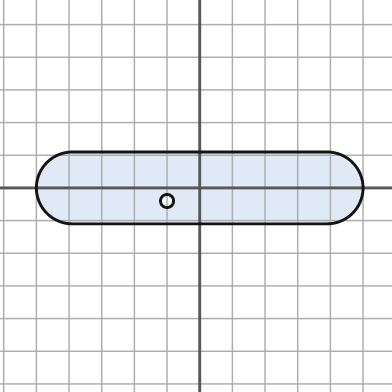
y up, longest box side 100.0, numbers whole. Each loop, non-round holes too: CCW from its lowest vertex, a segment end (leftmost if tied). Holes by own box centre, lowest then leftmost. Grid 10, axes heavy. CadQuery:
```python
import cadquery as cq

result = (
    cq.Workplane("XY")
    .moveTo(-39.0, -11.0)
    .lineTo(39.0, -11.0)
    .threePointArc((50.0, 0.0), (39.0, 11.0))
    .lineTo(-39.0, 11.0)
    .threePointArc((-50.0, 0.0), (-39.0, -11.0))
    .close()
    .moveTo(-10.0, -4.0)
    .circle(2.0)
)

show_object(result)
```